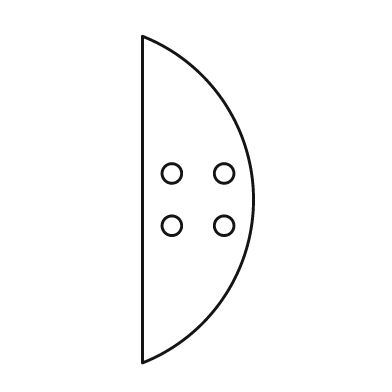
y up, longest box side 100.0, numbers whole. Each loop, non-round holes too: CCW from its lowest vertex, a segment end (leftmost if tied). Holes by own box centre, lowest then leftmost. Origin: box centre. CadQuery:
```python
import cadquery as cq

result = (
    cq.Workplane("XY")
    .moveTo(-17.0, -50.0)
    .threePointArc((17.0, 0.0), (-17.0, 50.0))
    .close()
    .moveTo(-8.0, -8.0)
    .circle(3.0)
    .moveTo(8.0, -8.0)
    .circle(3.0)
    .moveTo(-8.0, 8.0)
    .circle(3.0)
    .moveTo(8.0, 8.0)
    .circle(3.0)
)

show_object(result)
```